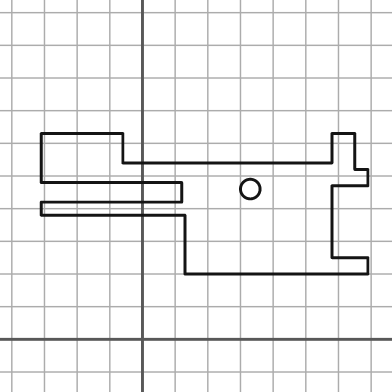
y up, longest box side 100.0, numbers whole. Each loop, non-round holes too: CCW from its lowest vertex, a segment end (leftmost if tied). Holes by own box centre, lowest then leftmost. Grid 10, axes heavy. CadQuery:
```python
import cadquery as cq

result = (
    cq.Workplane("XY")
    .moveTo(13.0, 20.0)
    .lineTo(69.0, 20.0)
    .lineTo(69.0, 25.0)
    .lineTo(58.0, 25.0)
    .lineTo(58.0, 47.0)
    .lineTo(69.0, 47.0)
    .lineTo(69.0, 52.0)
    .lineTo(65.0, 52.0)
    .lineTo(65.0, 63.0)
    .lineTo(58.0, 63.0)
    .lineTo(58.0, 54.0)
    .lineTo(-6.0, 54.0)
    .lineTo(-6.0, 63.0)
    .lineTo(-31.0, 63.0)
    .lineTo(-31.0, 48.0)
    .lineTo(12.0, 48.0)
    .lineTo(12.0, 42.0)
    .lineTo(-31.0, 42.0)
    .lineTo(-31.0, 38.0)
    .lineTo(13.0, 38.0)
    .close()
    .moveTo(33.0, 46.0)
    .circle(3.0)
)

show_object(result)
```